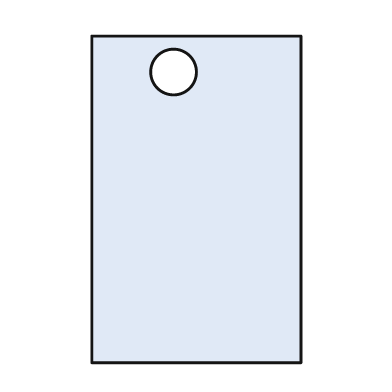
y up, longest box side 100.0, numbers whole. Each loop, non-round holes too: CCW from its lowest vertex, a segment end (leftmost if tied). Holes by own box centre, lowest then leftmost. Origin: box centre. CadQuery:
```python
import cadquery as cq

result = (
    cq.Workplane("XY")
    .moveTo(-32.0, -50.0)
    .lineTo(32.0, -50.0)
    .lineTo(32.0, 50.0)
    .lineTo(-32.0, 50.0)
    .close()
    .moveTo(-7.0, 39.0)
    .circle(7.0)
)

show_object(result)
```